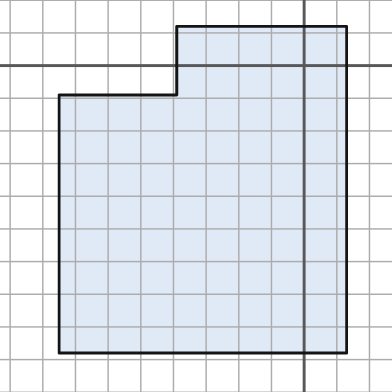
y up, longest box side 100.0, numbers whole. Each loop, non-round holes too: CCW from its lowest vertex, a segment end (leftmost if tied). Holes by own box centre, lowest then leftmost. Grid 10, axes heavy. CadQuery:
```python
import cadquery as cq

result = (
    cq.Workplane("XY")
    .moveTo(-75.0, -88.0)
    .lineTo(13.0, -88.0)
    .lineTo(13.0, 12.0)
    .lineTo(-39.0, 12.0)
    .lineTo(-39.0, -9.0)
    .lineTo(-75.0, -9.0)
    .close()
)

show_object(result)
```